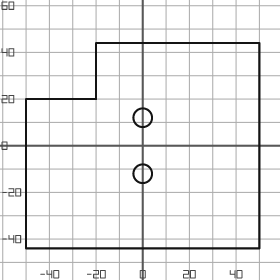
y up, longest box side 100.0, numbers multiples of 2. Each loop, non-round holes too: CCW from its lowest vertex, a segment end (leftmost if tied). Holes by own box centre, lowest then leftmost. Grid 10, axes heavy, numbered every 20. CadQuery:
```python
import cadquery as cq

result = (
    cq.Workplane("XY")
    .moveTo(-50.0, -44.0)
    .lineTo(50.0, -44.0)
    .lineTo(50.0, 44.0)
    .lineTo(-20.0, 44.0)
    .lineTo(-20.0, 20.0)
    .lineTo(-50.0, 20.0)
    .close()
    .moveTo(0.0, -12.0)
    .circle(4.0)
    .moveTo(0.0, 12.0)
    .circle(4.0)
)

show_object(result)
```